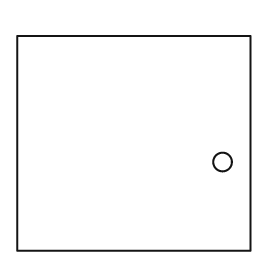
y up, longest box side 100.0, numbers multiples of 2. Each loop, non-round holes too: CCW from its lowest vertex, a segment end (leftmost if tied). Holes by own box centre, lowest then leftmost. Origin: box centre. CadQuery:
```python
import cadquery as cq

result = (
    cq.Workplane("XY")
    .moveTo(-50.0, -46.0)
    .lineTo(50.0, -46.0)
    .lineTo(50.0, 46.0)
    .lineTo(-50.0, 46.0)
    .close()
    .moveTo(38.0, -8.0)
    .circle(4.0)
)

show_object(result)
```